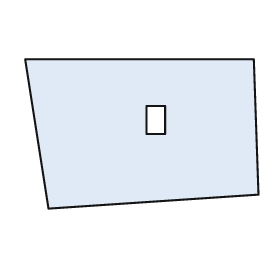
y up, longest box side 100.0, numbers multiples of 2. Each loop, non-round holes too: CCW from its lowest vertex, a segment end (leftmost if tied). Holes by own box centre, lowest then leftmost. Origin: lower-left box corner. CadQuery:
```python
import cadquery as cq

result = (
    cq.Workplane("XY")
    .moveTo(10.0, 0.0)
    .lineTo(100.0, 6.0)
    .lineTo(98.0, 64.0)
    .lineTo(0.0, 64.0)
    .close()
    .moveTo(52.0, 32.0)
    .lineTo(60.0, 32.0)
    .lineTo(60.0, 44.0)
    .lineTo(52.0, 44.0)
    .close()
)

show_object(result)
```